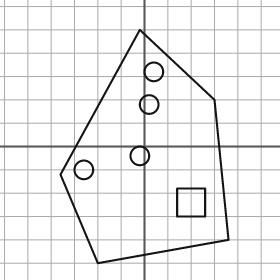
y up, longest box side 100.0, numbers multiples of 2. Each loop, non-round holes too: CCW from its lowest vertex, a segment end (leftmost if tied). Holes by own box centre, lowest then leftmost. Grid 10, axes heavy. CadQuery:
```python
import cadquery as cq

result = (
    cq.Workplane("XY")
    .moveTo(-20.0, -50.0)
    .lineTo(36.0, -40.0)
    .lineTo(30.0, 20.0)
    .lineTo(-2.0, 50.0)
    .lineTo(-36.0, -12.0)
    .close()
    .moveTo(14.0, -30.0)
    .lineTo(26.0, -30.0)
    .lineTo(26.0, -18.0)
    .lineTo(14.0, -18.0)
    .close()
    .moveTo(-26.0, -10.0)
    .circle(4.0)
    .moveTo(-2.0, -4.0)
    .circle(4.0)
    .moveTo(2.0, 18.0)
    .circle(4.0)
    .moveTo(4.0, 32.0)
    .circle(4.0)
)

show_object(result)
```